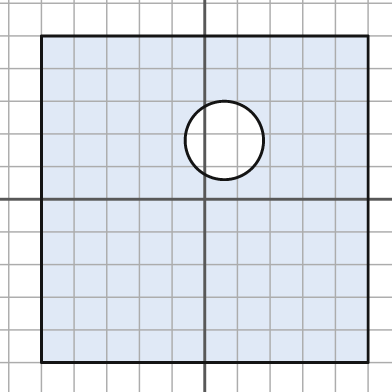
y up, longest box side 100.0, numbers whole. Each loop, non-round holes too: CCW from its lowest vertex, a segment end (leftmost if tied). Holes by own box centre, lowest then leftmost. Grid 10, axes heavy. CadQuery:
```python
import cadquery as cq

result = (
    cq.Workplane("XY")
    .moveTo(-50.0, -50.0)
    .lineTo(50.0, -50.0)
    .lineTo(50.0, 50.0)
    .lineTo(-50.0, 50.0)
    .close()
    .moveTo(6.0, 18.0)
    .circle(12.0)
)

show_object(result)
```